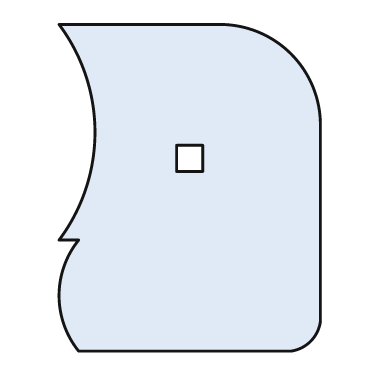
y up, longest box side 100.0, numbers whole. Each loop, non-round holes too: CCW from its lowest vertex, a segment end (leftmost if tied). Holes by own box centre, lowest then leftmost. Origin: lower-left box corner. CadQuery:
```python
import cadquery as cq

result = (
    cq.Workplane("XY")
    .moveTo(6.0, 0.0)
    .lineTo(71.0, 0.0)
    .threePointArc((77.0, 3.0), (80.0, 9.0))
    .lineTo(80.0, 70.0)
    .threePointArc((71.0, 91.0), (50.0, 100.0))
    .lineTo(0.0, 100.0)
    .threePointArc((11.0, 67.0), (0.0, 34.0))
    .lineTo(6.0, 34.0)
    .threePointArc((0.0, 17.0), (6.0, 0.0))
    .close()
    .moveTo(36.0, 55.0)
    .lineTo(44.0, 55.0)
    .lineTo(44.0, 63.0)
    .lineTo(36.0, 63.0)
    .close()
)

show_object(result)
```